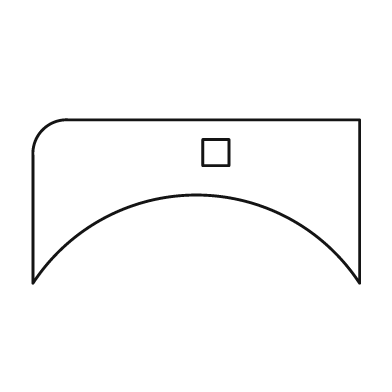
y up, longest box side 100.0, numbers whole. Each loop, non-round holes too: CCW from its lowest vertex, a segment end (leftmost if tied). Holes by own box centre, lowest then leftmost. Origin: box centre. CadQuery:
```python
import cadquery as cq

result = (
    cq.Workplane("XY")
    .moveTo(-50.0, -25.0)
    .threePointArc((0.0, 2.0), (50.0, -25.0))
    .lineTo(50.0, 25.0)
    .lineTo(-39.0, 25.0)
    .threePointArc((-47.0, 22.0), (-50.0, 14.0))
    .close()
    .moveTo(2.0, 11.0)
    .lineTo(10.0, 11.0)
    .lineTo(10.0, 19.0)
    .lineTo(2.0, 19.0)
    .close()
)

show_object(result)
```